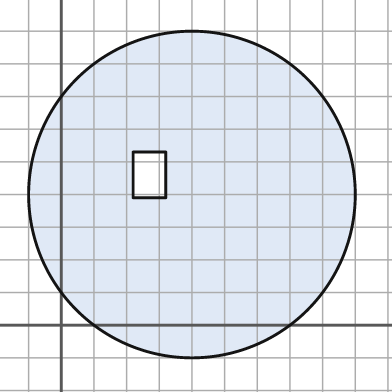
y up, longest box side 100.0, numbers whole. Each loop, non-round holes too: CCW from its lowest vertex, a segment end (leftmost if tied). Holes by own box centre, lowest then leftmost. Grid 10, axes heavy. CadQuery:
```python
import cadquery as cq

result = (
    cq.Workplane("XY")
    .moveTo(40.0, 40.0)
    .circle(50.0)
    .moveTo(22.0, 39.0)
    .lineTo(32.0, 39.0)
    .lineTo(32.0, 53.0)
    .lineTo(22.0, 53.0)
    .close()
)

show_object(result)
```